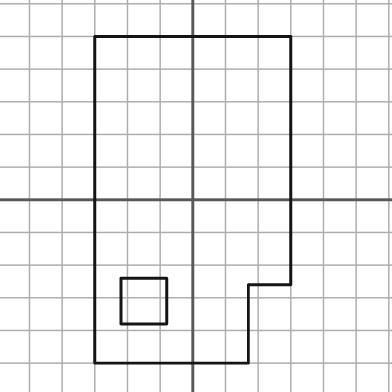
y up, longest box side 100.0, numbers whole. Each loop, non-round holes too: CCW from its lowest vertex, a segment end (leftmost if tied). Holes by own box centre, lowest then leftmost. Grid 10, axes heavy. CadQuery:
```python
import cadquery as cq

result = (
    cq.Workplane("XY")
    .moveTo(-30.0, -50.0)
    .lineTo(17.0, -50.0)
    .lineTo(17.0, -26.0)
    .lineTo(30.0, -26.0)
    .lineTo(30.0, 50.0)
    .lineTo(-30.0, 50.0)
    .close()
    .moveTo(-22.0, -38.0)
    .lineTo(-8.0, -38.0)
    .lineTo(-8.0, -24.0)
    .lineTo(-22.0, -24.0)
    .close()
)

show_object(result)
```